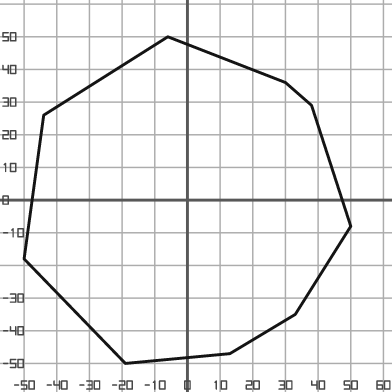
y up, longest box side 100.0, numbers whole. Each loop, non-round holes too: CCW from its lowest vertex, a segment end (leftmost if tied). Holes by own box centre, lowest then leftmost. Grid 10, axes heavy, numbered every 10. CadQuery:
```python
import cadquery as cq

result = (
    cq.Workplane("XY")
    .moveTo(-19.0, -50.0)
    .lineTo(13.0, -47.0)
    .lineTo(33.0, -35.0)
    .lineTo(50.0, -8.0)
    .lineTo(38.0, 29.0)
    .lineTo(30.0, 36.0)
    .lineTo(-6.0, 50.0)
    .lineTo(-44.0, 26.0)
    .lineTo(-50.0, -18.0)
    .close()
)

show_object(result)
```